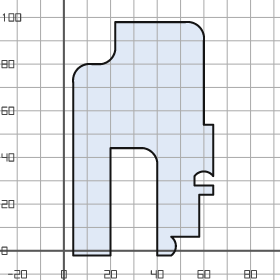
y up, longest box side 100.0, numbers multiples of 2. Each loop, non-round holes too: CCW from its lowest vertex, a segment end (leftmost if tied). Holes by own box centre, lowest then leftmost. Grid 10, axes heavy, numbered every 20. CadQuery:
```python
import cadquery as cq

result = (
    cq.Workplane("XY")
    .moveTo(4.0, -2.0)
    .lineTo(20.0, -2.0)
    .lineTo(20.0, 44.0)
    .lineTo(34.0, 44.0)
    .threePointArc((38.0, 42.0), (40.0, 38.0))
    .lineTo(40.0, -2.0)
    .lineTo(46.0, -2.0)
    .threePointArc((48.0, 2.0), (46.0, 6.0))
    .lineTo(58.0, 6.0)
    .lineTo(58.0, 24.0)
    .lineTo(64.0, 24.0)
    .lineTo(64.0, 28.0)
    .lineTo(56.0, 28.0)
    .lineTo(56.0, 32.0)
    .threePointArc((60.0, 34.0), (64.0, 32.0))
    .lineTo(64.0, 54.0)
    .lineTo(60.0, 54.0)
    .lineTo(60.0, 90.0)
    .threePointArc((58.0, 96.0), (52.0, 98.0))
    .lineTo(22.0, 98.0)
    .lineTo(22.0, 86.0)
    .threePointArc((20.0, 82.0), (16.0, 80.0))
    .lineTo(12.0, 80.0)
    .threePointArc((6.0, 78.0), (4.0, 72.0))
    .close()
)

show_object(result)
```